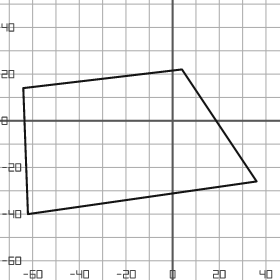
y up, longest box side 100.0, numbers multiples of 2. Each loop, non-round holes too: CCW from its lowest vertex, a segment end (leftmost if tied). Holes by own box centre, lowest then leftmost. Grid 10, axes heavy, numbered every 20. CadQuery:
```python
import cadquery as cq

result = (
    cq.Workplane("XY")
    .moveTo(-62.0, -40.0)
    .lineTo(36.0, -26.0)
    .lineTo(4.0, 22.0)
    .lineTo(-64.0, 14.0)
    .close()
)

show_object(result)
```